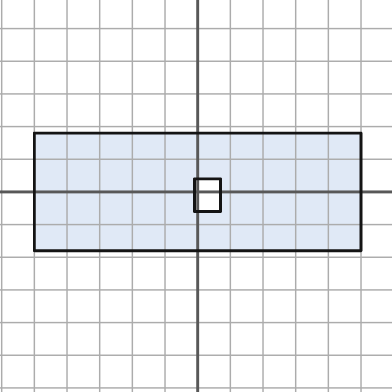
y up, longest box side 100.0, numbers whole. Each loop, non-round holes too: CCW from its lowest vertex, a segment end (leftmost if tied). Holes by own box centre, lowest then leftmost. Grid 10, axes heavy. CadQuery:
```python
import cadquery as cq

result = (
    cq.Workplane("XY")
    .moveTo(-50.0, -18.0)
    .lineTo(50.0, -18.0)
    .lineTo(50.0, 18.0)
    .lineTo(-50.0, 18.0)
    .close()
    .moveTo(-1.0, -6.0)
    .lineTo(7.0, -6.0)
    .lineTo(7.0, 4.0)
    .lineTo(-1.0, 4.0)
    .close()
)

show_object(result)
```